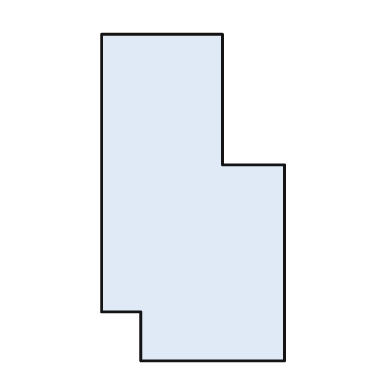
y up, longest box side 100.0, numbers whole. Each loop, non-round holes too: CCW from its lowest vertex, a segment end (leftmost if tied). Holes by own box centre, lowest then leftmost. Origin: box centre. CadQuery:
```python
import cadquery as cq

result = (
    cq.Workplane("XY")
    .moveTo(-16.0, -50.0)
    .lineTo(28.0, -50.0)
    .lineTo(28.0, 10.0)
    .lineTo(9.0, 10.0)
    .lineTo(9.0, 50.0)
    .lineTo(-28.0, 50.0)
    .lineTo(-28.0, -35.0)
    .lineTo(-16.0, -35.0)
    .close()
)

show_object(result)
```